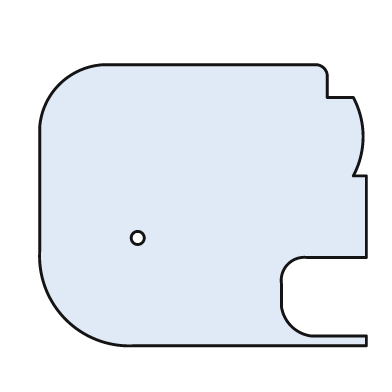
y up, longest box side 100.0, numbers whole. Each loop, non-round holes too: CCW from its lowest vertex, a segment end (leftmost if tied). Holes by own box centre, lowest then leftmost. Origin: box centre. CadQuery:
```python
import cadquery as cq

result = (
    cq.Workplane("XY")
    .moveTo(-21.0, -43.0)
    .lineTo(50.0, -43.0)
    .lineTo(50.0, -40.0)
    .lineTo(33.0, -40.0)
    .threePointArc((27.0, -37.0), (24.0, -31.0))
    .lineTo(24.0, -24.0)
    .threePointArc((26.0, -18.0), (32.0, -16.0))
    .lineTo(50.0, -16.0)
    .lineTo(50.0, 9.0)
    .lineTo(46.0, 9.0)
    .threePointArc((49.0, 21.0), (46.0, 33.0))
    .lineTo(38.0, 33.0)
    .lineTo(38.0, 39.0)
    .threePointArc((37.0, 42.0), (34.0, 43.0))
    .lineTo(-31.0, 43.0)
    .threePointArc((-44.0, 37.0), (-50.0, 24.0))
    .lineTo(-50.0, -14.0)
    .threePointArc((-42.0, -35.0), (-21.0, -43.0))
    .close()
    .moveTo(-20.0, -10.0)
    .circle(2.0)
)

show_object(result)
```